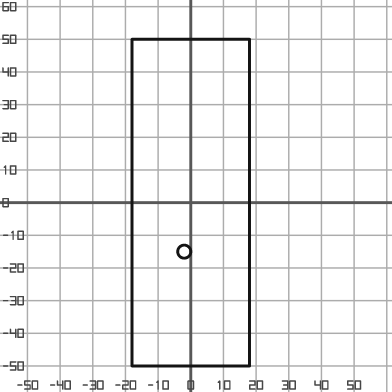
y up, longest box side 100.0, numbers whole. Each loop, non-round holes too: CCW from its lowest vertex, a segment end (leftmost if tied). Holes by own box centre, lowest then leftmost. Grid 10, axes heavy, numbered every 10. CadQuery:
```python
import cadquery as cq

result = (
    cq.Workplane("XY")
    .moveTo(-18.0, -50.0)
    .lineTo(18.0, -50.0)
    .lineTo(18.0, 50.0)
    .lineTo(-18.0, 50.0)
    .close()
    .moveTo(-2.0, -15.0)
    .circle(2.0)
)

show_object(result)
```